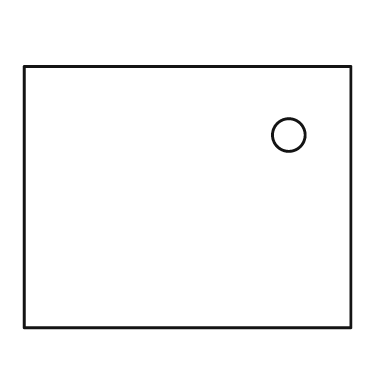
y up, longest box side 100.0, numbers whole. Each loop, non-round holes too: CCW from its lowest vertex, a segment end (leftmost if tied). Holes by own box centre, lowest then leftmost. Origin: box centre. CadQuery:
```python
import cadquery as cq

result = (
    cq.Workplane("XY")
    .moveTo(-50.0, -40.0)
    .lineTo(50.0, -40.0)
    .lineTo(50.0, 40.0)
    .lineTo(-50.0, 40.0)
    .close()
    .moveTo(31.0, 19.0)
    .circle(5.0)
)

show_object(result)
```